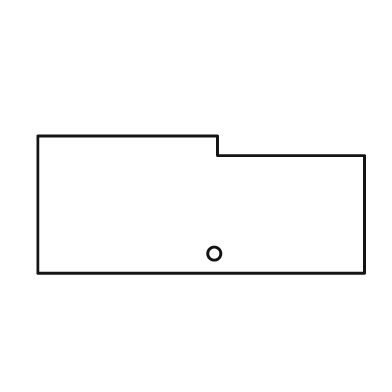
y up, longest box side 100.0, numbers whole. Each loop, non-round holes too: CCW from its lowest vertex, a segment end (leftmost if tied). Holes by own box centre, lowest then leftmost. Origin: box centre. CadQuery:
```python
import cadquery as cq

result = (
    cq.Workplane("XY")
    .moveTo(-50.0, -21.0)
    .lineTo(50.0, -21.0)
    .lineTo(50.0, 15.0)
    .lineTo(5.0, 15.0)
    .lineTo(5.0, 21.0)
    .lineTo(-50.0, 21.0)
    .close()
    .moveTo(4.0, -15.0)
    .circle(2.0)
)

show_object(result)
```